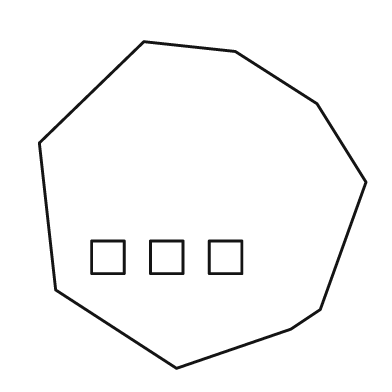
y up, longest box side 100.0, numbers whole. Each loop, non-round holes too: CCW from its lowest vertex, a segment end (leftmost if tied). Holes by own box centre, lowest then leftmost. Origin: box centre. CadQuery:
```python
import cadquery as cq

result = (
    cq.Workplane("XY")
    .moveTo(-8.0, -50.0)
    .lineTo(27.0, -38.0)
    .lineTo(36.0, -32.0)
    .lineTo(50.0, 7.0)
    .lineTo(35.0, 31.0)
    .lineTo(10.0, 47.0)
    .lineTo(-18.0, 50.0)
    .lineTo(-50.0, 19.0)
    .lineTo(-45.0, -26.0)
    .close()
    .moveTo(-34.0, -21.0)
    .lineTo(-24.0, -21.0)
    .lineTo(-24.0, -11.0)
    .lineTo(-34.0, -11.0)
    .close()
    .moveTo(-16.0, -21.0)
    .lineTo(-6.0, -21.0)
    .lineTo(-6.0, -11.0)
    .lineTo(-16.0, -11.0)
    .close()
    .moveTo(2.0, -21.0)
    .lineTo(12.0, -21.0)
    .lineTo(12.0, -11.0)
    .lineTo(2.0, -11.0)
    .close()
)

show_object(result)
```